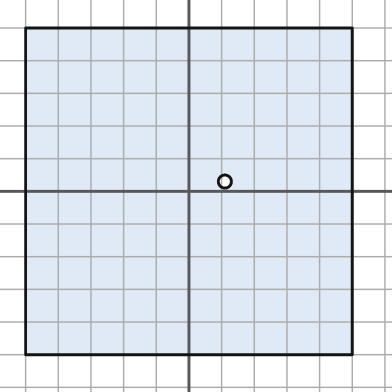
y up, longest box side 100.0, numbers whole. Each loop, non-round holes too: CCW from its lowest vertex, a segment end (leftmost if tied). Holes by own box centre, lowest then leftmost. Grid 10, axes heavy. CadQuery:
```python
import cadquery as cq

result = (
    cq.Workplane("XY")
    .moveTo(-50.0, -50.0)
    .lineTo(50.0, -50.0)
    .lineTo(50.0, 50.0)
    .lineTo(-50.0, 50.0)
    .close()
    .moveTo(11.0, 3.0)
    .circle(2.0)
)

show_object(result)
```